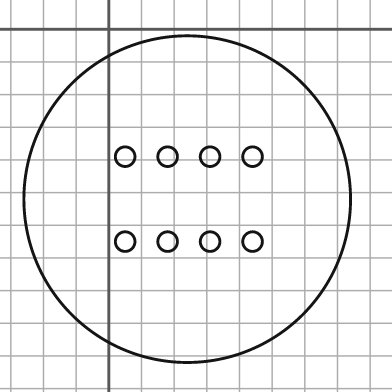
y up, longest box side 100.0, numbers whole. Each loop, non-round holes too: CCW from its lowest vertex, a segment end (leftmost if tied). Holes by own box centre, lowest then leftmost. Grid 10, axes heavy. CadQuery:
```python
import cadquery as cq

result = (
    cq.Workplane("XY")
    .moveTo(24.0, -52.0)
    .circle(50.0)
    .moveTo(5.0, -65.0)
    .circle(3.0)
    .moveTo(18.0, -65.0)
    .circle(3.0)
    .moveTo(31.0, -65.0)
    .circle(3.0)
    .moveTo(44.0, -65.0)
    .circle(3.0)
    .moveTo(5.0, -39.0)
    .circle(3.0)
    .moveTo(18.0, -39.0)
    .circle(3.0)
    .moveTo(31.0, -39.0)
    .circle(3.0)
    .moveTo(44.0, -39.0)
    .circle(3.0)
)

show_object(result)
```